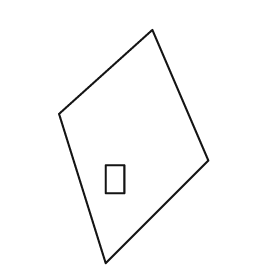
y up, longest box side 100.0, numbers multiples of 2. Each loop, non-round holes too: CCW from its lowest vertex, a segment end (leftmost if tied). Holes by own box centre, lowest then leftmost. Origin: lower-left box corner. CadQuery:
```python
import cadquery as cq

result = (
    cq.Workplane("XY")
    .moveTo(20.0, 0.0)
    .lineTo(64.0, 44.0)
    .lineTo(40.0, 100.0)
    .lineTo(0.0, 64.0)
    .close()
    .moveTo(20.0, 30.0)
    .lineTo(28.0, 30.0)
    .lineTo(28.0, 42.0)
    .lineTo(20.0, 42.0)
    .close()
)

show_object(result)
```